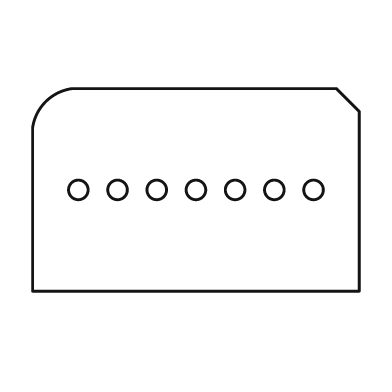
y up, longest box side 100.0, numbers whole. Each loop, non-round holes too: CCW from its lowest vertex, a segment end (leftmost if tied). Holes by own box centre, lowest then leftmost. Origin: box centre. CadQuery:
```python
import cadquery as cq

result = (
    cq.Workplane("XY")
    .moveTo(-50.0, -31.0)
    .lineTo(50.0, -31.0)
    .lineTo(50.0, 24.0)
    .lineTo(43.0, 31.0)
    .lineTo(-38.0, 31.0)
    .threePointArc((-46.0, 27.0), (-50.0, 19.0))
    .close()
    .moveTo(-36.0, 0.0)
    .circle(3.0)
    .moveTo(-24.0, 0.0)
    .circle(3.0)
    .moveTo(-12.0, 0.0)
    .circle(3.0)
    .moveTo(0.0, 0.0)
    .circle(3.0)
    .moveTo(12.0, 0.0)
    .circle(3.0)
    .moveTo(24.0, 0.0)
    .circle(3.0)
    .moveTo(36.0, 0.0)
    .circle(3.0)
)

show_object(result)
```